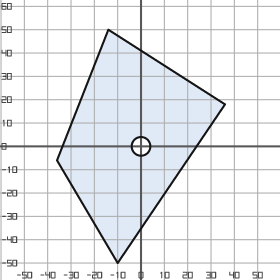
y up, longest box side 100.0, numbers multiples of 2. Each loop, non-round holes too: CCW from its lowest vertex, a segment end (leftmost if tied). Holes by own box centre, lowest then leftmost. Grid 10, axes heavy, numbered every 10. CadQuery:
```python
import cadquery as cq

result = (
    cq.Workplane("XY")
    .moveTo(-10.0, -50.0)
    .lineTo(36.0, 18.0)
    .lineTo(-14.0, 50.0)
    .lineTo(-36.0, -6.0)
    .close()
    .moveTo(0.0, 0.0)
    .circle(4.0)
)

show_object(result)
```